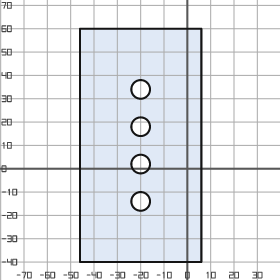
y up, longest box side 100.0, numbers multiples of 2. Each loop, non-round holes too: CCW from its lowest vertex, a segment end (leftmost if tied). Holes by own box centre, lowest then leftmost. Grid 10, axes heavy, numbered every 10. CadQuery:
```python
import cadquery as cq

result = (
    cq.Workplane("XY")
    .moveTo(-46.0, -40.0)
    .lineTo(6.0, -40.0)
    .lineTo(6.0, 60.0)
    .lineTo(-46.0, 60.0)
    .close()
    .moveTo(-20.0, -14.0)
    .circle(4.0)
    .moveTo(-20.0, 2.0)
    .circle(4.0)
    .moveTo(-20.0, 18.0)
    .circle(4.0)
    .moveTo(-20.0, 34.0)
    .circle(4.0)
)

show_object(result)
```